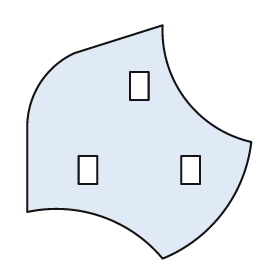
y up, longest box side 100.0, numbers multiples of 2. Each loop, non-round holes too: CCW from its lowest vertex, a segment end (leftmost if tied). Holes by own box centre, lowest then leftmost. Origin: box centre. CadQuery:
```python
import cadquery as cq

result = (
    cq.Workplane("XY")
    .moveTo(10.0, -50.0)
    .threePointArc((36.0, -30.0), (48.0, 0.0))
    .threePointArc((20.0, 18.0), (10.0, 50.0))
    .lineTo(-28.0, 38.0)
    .threePointArc((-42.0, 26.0), (-48.0, 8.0))
    .lineTo(-48.0, -30.0)
    .threePointArc((-16.0, -32.0), (10.0, -50.0))
    .close()
    .moveTo(-26.0, -18.0)
    .lineTo(-18.0, -18.0)
    .lineTo(-18.0, -6.0)
    .lineTo(-26.0, -6.0)
    .close()
    .moveTo(18.0, -18.0)
    .lineTo(26.0, -18.0)
    .lineTo(26.0, -6.0)
    .lineTo(18.0, -6.0)
    .close()
    .moveTo(-4.0, 18.0)
    .lineTo(4.0, 18.0)
    .lineTo(4.0, 30.0)
    .lineTo(-4.0, 30.0)
    .close()
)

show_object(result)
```